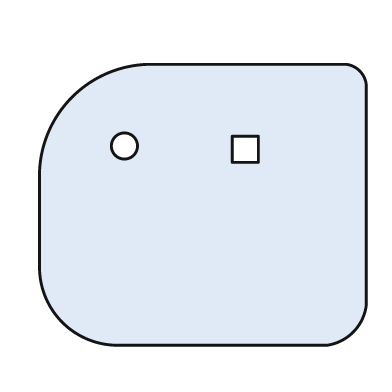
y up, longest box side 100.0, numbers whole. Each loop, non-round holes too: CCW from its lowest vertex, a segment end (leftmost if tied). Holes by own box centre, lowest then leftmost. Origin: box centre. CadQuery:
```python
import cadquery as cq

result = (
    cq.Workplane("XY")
    .moveTo(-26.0, -43.0)
    .lineTo(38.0, -43.0)
    .threePointArc((46.0, -39.0), (50.0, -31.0))
    .lineTo(50.0, 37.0)
    .threePointArc((48.0, 41.0), (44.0, 43.0))
    .lineTo(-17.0, 43.0)
    .threePointArc((-40.0, 33.0), (-50.0, 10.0))
    .lineTo(-50.0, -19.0)
    .threePointArc((-43.0, -36.0), (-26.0, -43.0))
    .close()
    .moveTo(9.0, 13.0)
    .lineTo(17.0, 13.0)
    .lineTo(17.0, 21.0)
    .lineTo(9.0, 21.0)
    .close()
    .moveTo(-24.0, 18.0)
    .circle(4.0)
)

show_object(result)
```